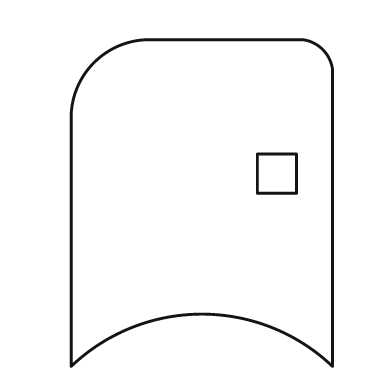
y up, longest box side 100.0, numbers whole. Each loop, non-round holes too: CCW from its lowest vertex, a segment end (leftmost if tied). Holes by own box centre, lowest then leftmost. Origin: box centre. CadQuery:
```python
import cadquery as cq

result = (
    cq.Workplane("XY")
    .moveTo(-40.0, -50.0)
    .threePointArc((0.0, -34.0), (40.0, -50.0))
    .lineTo(40.0, 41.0)
    .threePointArc((37.0, 47.0), (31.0, 50.0))
    .lineTo(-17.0, 50.0)
    .threePointArc((-33.0, 43.0), (-40.0, 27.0))
    .close()
    .moveTo(17.0, 3.0)
    .lineTo(29.0, 3.0)
    .lineTo(29.0, 15.0)
    .lineTo(17.0, 15.0)
    .close()
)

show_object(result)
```